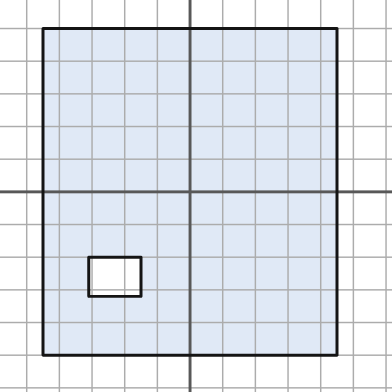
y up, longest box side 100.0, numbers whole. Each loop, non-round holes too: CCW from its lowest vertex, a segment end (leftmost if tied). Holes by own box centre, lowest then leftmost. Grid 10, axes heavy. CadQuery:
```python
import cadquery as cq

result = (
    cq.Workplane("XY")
    .moveTo(-45.0, -50.0)
    .lineTo(45.0, -50.0)
    .lineTo(45.0, 50.0)
    .lineTo(-45.0, 50.0)
    .close()
    .moveTo(-31.0, -32.0)
    .lineTo(-15.0, -32.0)
    .lineTo(-15.0, -20.0)
    .lineTo(-31.0, -20.0)
    .close()
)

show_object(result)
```